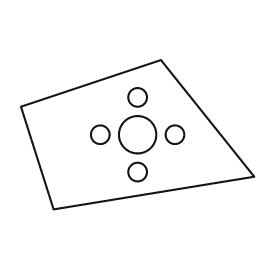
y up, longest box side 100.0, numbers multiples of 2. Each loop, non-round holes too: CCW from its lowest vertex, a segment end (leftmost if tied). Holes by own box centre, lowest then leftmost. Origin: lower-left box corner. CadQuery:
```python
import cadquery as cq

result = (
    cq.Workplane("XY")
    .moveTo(14.0, 0.0)
    .lineTo(100.0, 14.0)
    .lineTo(60.0, 64.0)
    .lineTo(0.0, 44.0)
    .close()
    .moveTo(50.0, 16.0)
    .circle(4.0)
    .moveTo(34.0, 32.0)
    .circle(4.0)
    .moveTo(50.0, 32.0)
    .circle(8.0)
    .moveTo(66.0, 32.0)
    .circle(4.0)
    .moveTo(50.0, 48.0)
    .circle(4.0)
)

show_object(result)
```